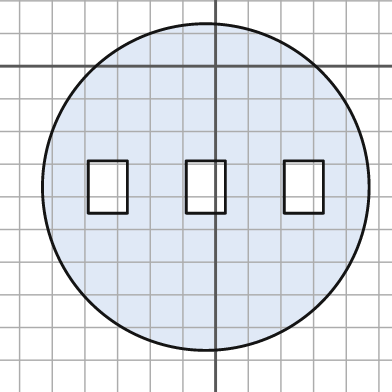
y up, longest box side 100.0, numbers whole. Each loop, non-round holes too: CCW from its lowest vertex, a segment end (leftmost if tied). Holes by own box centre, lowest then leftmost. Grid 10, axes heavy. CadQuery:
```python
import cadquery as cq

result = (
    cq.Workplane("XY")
    .moveTo(-3.0, -37.0)
    .circle(50.0)
    .moveTo(-39.0, -45.0)
    .lineTo(-27.0, -45.0)
    .lineTo(-27.0, -29.0)
    .lineTo(-39.0, -29.0)
    .close()
    .moveTo(-9.0, -45.0)
    .lineTo(3.0, -45.0)
    .lineTo(3.0, -29.0)
    .lineTo(-9.0, -29.0)
    .close()
    .moveTo(21.0, -45.0)
    .lineTo(33.0, -45.0)
    .lineTo(33.0, -29.0)
    .lineTo(21.0, -29.0)
    .close()
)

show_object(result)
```